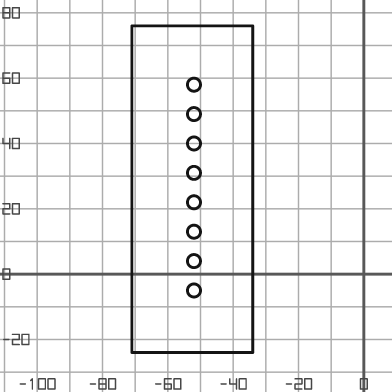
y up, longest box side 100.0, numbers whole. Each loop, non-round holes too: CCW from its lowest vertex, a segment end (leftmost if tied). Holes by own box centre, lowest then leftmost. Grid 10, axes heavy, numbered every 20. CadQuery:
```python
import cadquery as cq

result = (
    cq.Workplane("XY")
    .moveTo(-71.0, -24.0)
    .lineTo(-34.0, -24.0)
    .lineTo(-34.0, 76.0)
    .lineTo(-71.0, 76.0)
    .close()
    .moveTo(-52.0, -5.0)
    .circle(2.0)
    .moveTo(-52.0, 4.0)
    .circle(2.0)
    .moveTo(-52.0, 13.0)
    .circle(2.0)
    .moveTo(-52.0, 22.0)
    .circle(2.0)
    .moveTo(-52.0, 31.0)
    .circle(2.0)
    .moveTo(-52.0, 40.0)
    .circle(2.0)
    .moveTo(-52.0, 49.0)
    .circle(2.0)
    .moveTo(-52.0, 58.0)
    .circle(2.0)
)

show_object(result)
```